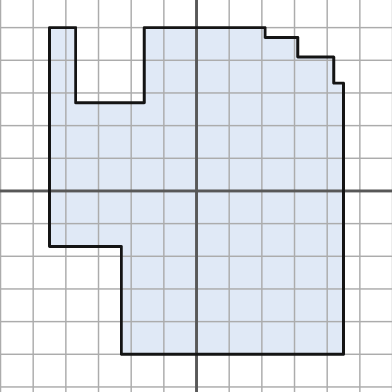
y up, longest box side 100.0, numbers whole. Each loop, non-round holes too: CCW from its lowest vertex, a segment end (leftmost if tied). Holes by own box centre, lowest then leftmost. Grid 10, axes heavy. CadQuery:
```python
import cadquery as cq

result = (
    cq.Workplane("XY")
    .moveTo(-23.0, -50.0)
    .lineTo(45.0, -50.0)
    .lineTo(45.0, 33.0)
    .lineTo(42.0, 33.0)
    .lineTo(42.0, 41.0)
    .lineTo(31.0, 41.0)
    .lineTo(31.0, 47.0)
    .lineTo(21.0, 47.0)
    .lineTo(21.0, 50.0)
    .lineTo(-16.0, 50.0)
    .lineTo(-16.0, 27.0)
    .lineTo(-37.0, 27.0)
    .lineTo(-37.0, 50.0)
    .lineTo(-45.0, 50.0)
    .lineTo(-45.0, -17.0)
    .lineTo(-23.0, -17.0)
    .close()
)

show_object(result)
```